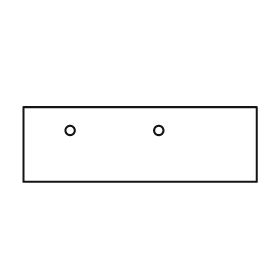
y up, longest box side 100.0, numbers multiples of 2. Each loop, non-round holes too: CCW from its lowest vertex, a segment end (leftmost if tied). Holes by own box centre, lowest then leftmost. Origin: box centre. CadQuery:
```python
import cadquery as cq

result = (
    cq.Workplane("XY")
    .moveTo(-50.0, -16.0)
    .lineTo(50.0, -16.0)
    .lineTo(50.0, 16.0)
    .lineTo(-50.0, 16.0)
    .close()
    .moveTo(-30.0, 6.0)
    .circle(2.0)
    .moveTo(8.0, 6.0)
    .circle(2.0)
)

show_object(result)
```